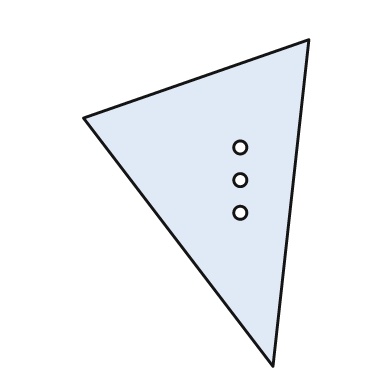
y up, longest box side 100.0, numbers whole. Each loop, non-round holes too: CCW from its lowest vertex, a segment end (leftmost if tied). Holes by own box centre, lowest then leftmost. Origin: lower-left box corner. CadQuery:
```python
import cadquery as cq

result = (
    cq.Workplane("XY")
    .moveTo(58.0, 0.0)
    .lineTo(69.0, 100.0)
    .lineTo(0.0, 76.0)
    .close()
    .moveTo(48.0, 47.0)
    .circle(2.0)
    .moveTo(48.0, 57.0)
    .circle(2.0)
    .moveTo(48.0, 67.0)
    .circle(2.0)
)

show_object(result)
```